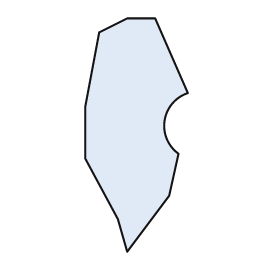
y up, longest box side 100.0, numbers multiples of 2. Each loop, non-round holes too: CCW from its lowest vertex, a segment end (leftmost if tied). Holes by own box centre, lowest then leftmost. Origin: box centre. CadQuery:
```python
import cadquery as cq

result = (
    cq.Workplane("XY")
    .moveTo(-4.0, -50.0)
    .lineTo(14.0, -26.0)
    .lineTo(18.0, -8.0)
    .threePointArc((12.0, 6.0), (22.0, 18.0))
    .lineTo(8.0, 50.0)
    .lineTo(-4.0, 50.0)
    .lineTo(-16.0, 44.0)
    .lineTo(-22.0, 12.0)
    .lineTo(-22.0, -10.0)
    .lineTo(-8.0, -36.0)
    .close()
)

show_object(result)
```